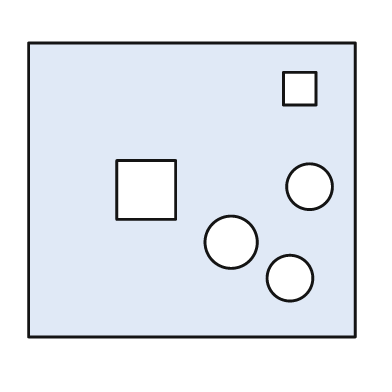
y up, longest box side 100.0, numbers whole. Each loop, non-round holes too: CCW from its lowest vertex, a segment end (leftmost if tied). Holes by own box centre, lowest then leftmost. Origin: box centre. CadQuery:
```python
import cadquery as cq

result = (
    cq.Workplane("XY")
    .moveTo(-50.0, -45.0)
    .lineTo(50.0, -45.0)
    .lineTo(50.0, 45.0)
    .lineTo(-50.0, 45.0)
    .close()
    .moveTo(30.0, -27.0)
    .circle(7.0)
    .moveTo(12.0, -16.0)
    .circle(8.0)
    .moveTo(-23.0, -9.0)
    .lineTo(-5.0, -9.0)
    .lineTo(-5.0, 9.0)
    .lineTo(-23.0, 9.0)
    .close()
    .moveTo(36.0, 1.0)
    .circle(7.0)
    .moveTo(28.0, 26.0)
    .lineTo(38.0, 26.0)
    .lineTo(38.0, 36.0)
    .lineTo(28.0, 36.0)
    .close()
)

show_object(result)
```